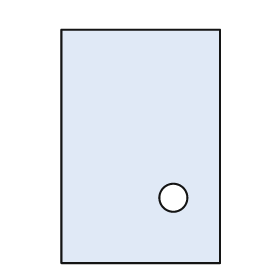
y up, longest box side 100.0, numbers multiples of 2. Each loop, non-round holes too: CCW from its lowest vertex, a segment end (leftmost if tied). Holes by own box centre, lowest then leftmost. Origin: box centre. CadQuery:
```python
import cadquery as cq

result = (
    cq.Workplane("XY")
    .moveTo(-34.0, -50.0)
    .lineTo(34.0, -50.0)
    .lineTo(34.0, 50.0)
    .lineTo(-34.0, 50.0)
    .close()
    .moveTo(14.0, -22.0)
    .circle(6.0)
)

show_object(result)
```